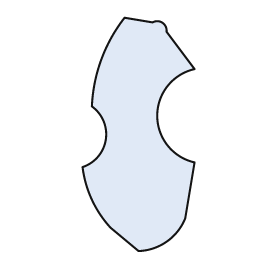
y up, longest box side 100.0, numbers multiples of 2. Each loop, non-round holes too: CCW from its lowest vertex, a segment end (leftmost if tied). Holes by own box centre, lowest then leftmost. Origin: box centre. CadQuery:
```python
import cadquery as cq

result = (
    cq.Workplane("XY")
    .moveTo(0.0, -50.0)
    .threePointArc((12.0, -46.0), (20.0, -36.0))
    .lineTo(24.0, -12.0)
    .threePointArc((8.0, 8.0), (24.0, 28.0))
    .lineTo(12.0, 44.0)
    .threePointArc((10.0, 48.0), (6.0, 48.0))
    .lineTo(-6.0, 50.0)
    .threePointArc((-16.0, 32.0), (-20.0, 12.0))
    .threePointArc((-14.0, -2.0), (-24.0, -14.0))
    .threePointArc((-20.0, -28.0), (-12.0, -40.0))
    .close()
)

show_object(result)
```